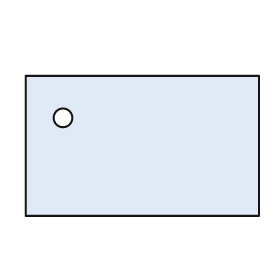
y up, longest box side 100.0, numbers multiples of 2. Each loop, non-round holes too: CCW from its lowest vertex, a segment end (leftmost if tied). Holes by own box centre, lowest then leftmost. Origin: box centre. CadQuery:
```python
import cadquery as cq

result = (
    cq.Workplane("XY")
    .moveTo(-50.0, -30.0)
    .lineTo(50.0, -30.0)
    .lineTo(50.0, 30.0)
    .lineTo(-50.0, 30.0)
    .close()
    .moveTo(-34.0, 12.0)
    .circle(4.0)
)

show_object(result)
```